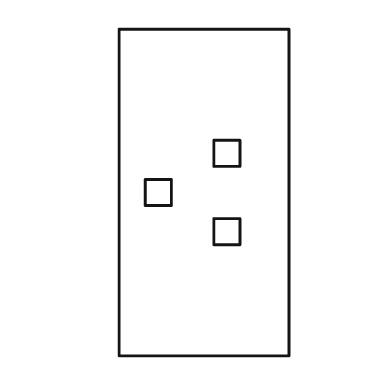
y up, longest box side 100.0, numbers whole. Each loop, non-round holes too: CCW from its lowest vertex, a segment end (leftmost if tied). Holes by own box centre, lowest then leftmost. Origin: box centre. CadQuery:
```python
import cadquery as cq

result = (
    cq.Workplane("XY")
    .moveTo(-26.0, -50.0)
    .lineTo(26.0, -50.0)
    .lineTo(26.0, 50.0)
    .lineTo(-26.0, 50.0)
    .close()
    .moveTo(3.0, -16.0)
    .lineTo(11.0, -16.0)
    .lineTo(11.0, -8.0)
    .lineTo(3.0, -8.0)
    .close()
    .moveTo(-18.0, -4.0)
    .lineTo(-10.0, -4.0)
    .lineTo(-10.0, 4.0)
    .lineTo(-18.0, 4.0)
    .close()
    .moveTo(3.0, 8.0)
    .lineTo(11.0, 8.0)
    .lineTo(11.0, 16.0)
    .lineTo(3.0, 16.0)
    .close()
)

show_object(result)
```